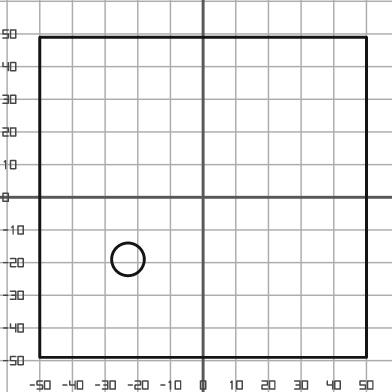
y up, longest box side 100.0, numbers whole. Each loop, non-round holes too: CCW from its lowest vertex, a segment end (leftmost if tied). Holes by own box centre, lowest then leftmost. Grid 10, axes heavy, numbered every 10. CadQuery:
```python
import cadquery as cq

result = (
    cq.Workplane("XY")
    .moveTo(-50.0, -49.0)
    .lineTo(50.0, -49.0)
    .lineTo(50.0, 49.0)
    .lineTo(-50.0, 49.0)
    .close()
    .moveTo(-23.0, -19.0)
    .circle(5.0)
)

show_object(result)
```